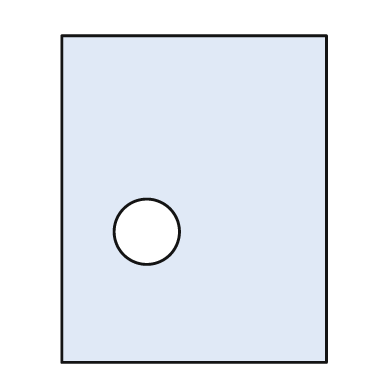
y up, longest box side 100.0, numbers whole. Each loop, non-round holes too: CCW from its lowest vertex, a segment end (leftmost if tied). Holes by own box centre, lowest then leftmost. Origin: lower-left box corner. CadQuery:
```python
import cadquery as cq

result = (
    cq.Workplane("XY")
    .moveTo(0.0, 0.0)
    .lineTo(81.0, 0.0)
    .lineTo(81.0, 100.0)
    .lineTo(0.0, 100.0)
    .close()
    .moveTo(26.0, 40.0)
    .circle(10.0)
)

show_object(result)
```